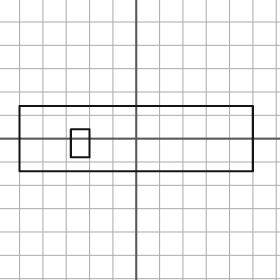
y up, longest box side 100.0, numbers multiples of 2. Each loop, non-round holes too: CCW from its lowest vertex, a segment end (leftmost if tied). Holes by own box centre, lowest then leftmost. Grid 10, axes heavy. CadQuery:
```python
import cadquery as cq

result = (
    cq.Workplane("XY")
    .moveTo(-50.0, -14.0)
    .lineTo(50.0, -14.0)
    .lineTo(50.0, 14.0)
    .lineTo(-50.0, 14.0)
    .close()
    .moveTo(-28.0, -8.0)
    .lineTo(-20.0, -8.0)
    .lineTo(-20.0, 4.0)
    .lineTo(-28.0, 4.0)
    .close()
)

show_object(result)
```